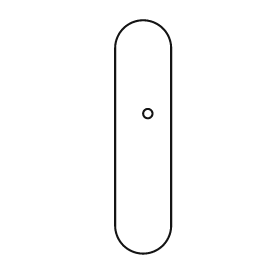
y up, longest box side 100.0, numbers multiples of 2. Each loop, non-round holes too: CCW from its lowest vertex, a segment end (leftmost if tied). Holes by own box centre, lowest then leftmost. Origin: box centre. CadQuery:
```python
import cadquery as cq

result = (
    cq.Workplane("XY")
    .moveTo(-12.0, -38.0)
    .threePointArc((0.0, -50.0), (12.0, -38.0))
    .lineTo(12.0, 38.0)
    .threePointArc((0.0, 50.0), (-12.0, 38.0))
    .close()
    .moveTo(2.0, 10.0)
    .circle(2.0)
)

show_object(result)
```